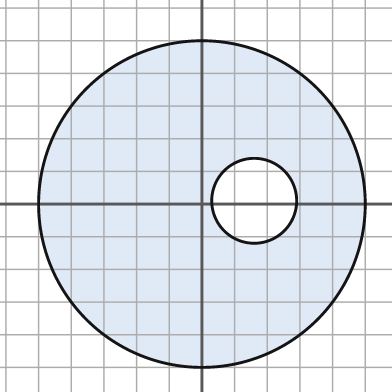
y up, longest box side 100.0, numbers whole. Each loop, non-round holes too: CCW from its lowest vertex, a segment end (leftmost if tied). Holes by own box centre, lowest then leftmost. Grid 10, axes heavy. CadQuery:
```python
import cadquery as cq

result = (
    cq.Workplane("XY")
    .moveTo(0.0, 0.0)
    .circle(50.0)
    .moveTo(16.0, 1.0)
    .circle(13.0)
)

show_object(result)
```